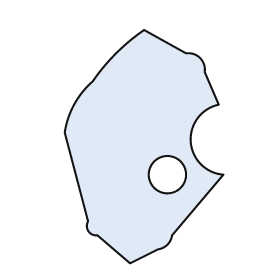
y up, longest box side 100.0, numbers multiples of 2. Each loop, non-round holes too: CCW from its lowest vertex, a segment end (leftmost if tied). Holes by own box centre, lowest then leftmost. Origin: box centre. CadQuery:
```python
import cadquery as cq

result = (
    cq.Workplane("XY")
    .moveTo(-6.0, -50.0)
    .lineTo(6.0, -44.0)
    .threePointArc((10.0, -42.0), (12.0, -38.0))
    .lineTo(34.0, -12.0)
    .threePointArc((20.0, 2.0), (32.0, 18.0))
    .lineTo(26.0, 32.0)
    .threePointArc((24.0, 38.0), (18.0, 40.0))
    .lineTo(0.0, 50.0)
    .threePointArc((-12.0, 40.0), (-22.0, 28.0))
    .threePointArc((-30.0, 18.0), (-34.0, 6.0))
    .lineTo(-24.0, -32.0)
    .threePointArc((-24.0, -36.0), (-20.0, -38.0))
    .close()
    .moveTo(10.0, -12.0)
    .circle(8.0)
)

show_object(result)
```